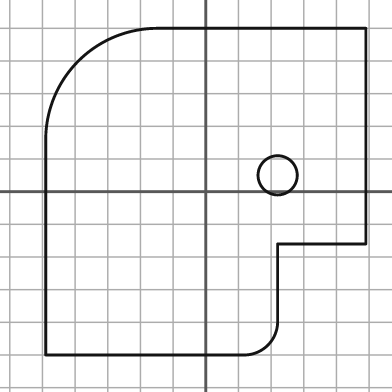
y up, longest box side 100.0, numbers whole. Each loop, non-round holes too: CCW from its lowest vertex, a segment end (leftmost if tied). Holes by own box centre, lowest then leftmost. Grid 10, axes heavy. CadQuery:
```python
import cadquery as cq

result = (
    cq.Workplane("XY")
    .moveTo(-49.0, -50.0)
    .lineTo(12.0, -50.0)
    .threePointArc((19.0, -47.0), (22.0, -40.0))
    .lineTo(22.0, -16.0)
    .lineTo(49.0, -16.0)
    .lineTo(49.0, 50.0)
    .lineTo(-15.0, 50.0)
    .threePointArc((-39.0, 40.0), (-49.0, 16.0))
    .close()
    .moveTo(22.0, 5.0)
    .circle(6.0)
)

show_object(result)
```